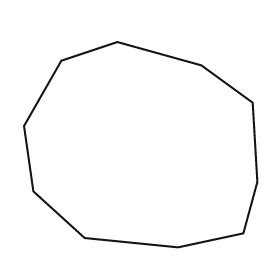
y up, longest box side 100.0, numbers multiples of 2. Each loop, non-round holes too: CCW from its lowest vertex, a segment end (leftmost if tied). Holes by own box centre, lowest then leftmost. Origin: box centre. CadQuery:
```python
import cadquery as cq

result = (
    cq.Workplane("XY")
    .moveTo(16.0, -44.0)
    .lineTo(44.0, -38.0)
    .lineTo(50.0, -16.0)
    .lineTo(48.0, 18.0)
    .lineTo(26.0, 34.0)
    .lineTo(-10.0, 44.0)
    .lineTo(-34.0, 36.0)
    .lineTo(-50.0, 8.0)
    .lineTo(-46.0, -20.0)
    .lineTo(-24.0, -40.0)
    .close()
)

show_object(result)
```